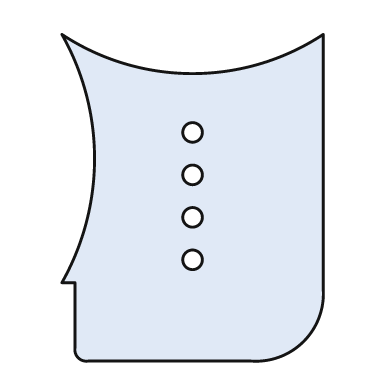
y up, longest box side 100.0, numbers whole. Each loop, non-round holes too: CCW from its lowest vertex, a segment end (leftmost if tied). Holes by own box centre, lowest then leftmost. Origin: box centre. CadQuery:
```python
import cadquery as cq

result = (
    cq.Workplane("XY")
    .moveTo(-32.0, -50.0)
    .lineTo(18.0, -50.0)
    .threePointArc((34.0, -44.0), (40.0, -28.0))
    .lineTo(40.0, 50.0)
    .threePointArc((0.0, 38.0), (-40.0, 50.0))
    .threePointArc((-30.0, 12.0), (-40.0, -26.0))
    .lineTo(-36.0, -26.0)
    .lineTo(-36.0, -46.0)
    .threePointArc((-35.0, -49.0), (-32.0, -50.0))
    .close()
    .moveTo(0.0, -19.0)
    .circle(3.0)
    .moveTo(0.0, -6.0)
    .circle(3.0)
    .moveTo(0.0, 7.0)
    .circle(3.0)
    .moveTo(0.0, 20.0)
    .circle(3.0)
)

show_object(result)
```